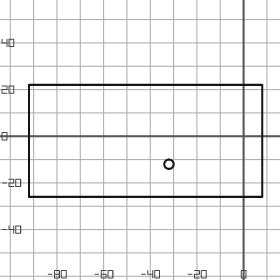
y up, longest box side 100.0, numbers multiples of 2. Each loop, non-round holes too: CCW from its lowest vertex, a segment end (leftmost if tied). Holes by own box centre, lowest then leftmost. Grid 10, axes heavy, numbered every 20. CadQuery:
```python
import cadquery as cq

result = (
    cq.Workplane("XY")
    .moveTo(-92.0, -26.0)
    .lineTo(8.0, -26.0)
    .lineTo(8.0, 22.0)
    .lineTo(-92.0, 22.0)
    .close()
    .moveTo(-32.0, -12.0)
    .circle(2.0)
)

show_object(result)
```